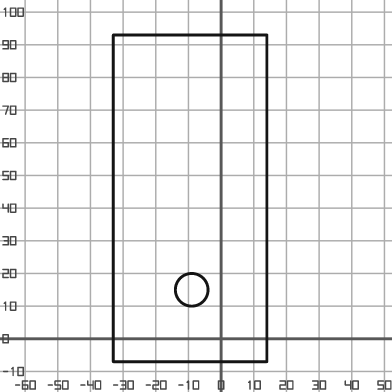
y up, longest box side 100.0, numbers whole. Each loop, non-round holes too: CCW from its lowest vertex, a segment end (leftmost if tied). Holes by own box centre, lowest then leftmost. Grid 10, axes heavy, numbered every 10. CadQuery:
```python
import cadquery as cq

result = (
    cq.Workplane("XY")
    .moveTo(-33.0, -7.0)
    .lineTo(14.0, -7.0)
    .lineTo(14.0, 93.0)
    .lineTo(-33.0, 93.0)
    .close()
    .moveTo(-9.0, 15.0)
    .circle(5.0)
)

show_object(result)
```